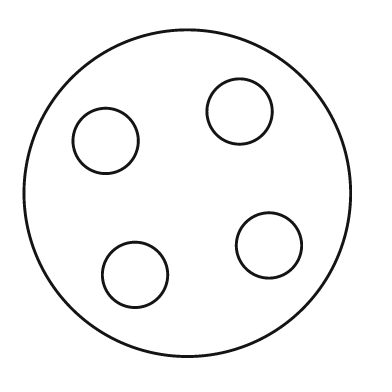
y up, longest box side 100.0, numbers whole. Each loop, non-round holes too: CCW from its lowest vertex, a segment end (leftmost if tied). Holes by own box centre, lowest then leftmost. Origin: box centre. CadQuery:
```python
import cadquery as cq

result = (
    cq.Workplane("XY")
    .moveTo(0.0, 0.0)
    .circle(50.0)
    .moveTo(-16.0, -25.0)
    .circle(10.0)
    .moveTo(25.0, -16.0)
    .circle(10.0)
    .moveTo(-25.0, 16.0)
    .circle(10.0)
    .moveTo(16.0, 25.0)
    .circle(10.0)
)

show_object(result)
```